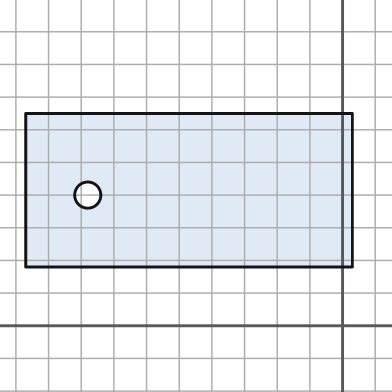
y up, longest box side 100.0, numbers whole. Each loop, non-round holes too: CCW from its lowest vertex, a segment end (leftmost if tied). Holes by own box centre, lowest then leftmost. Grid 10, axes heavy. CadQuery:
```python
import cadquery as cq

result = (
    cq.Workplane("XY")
    .moveTo(-97.0, 18.0)
    .lineTo(3.0, 18.0)
    .lineTo(3.0, 65.0)
    .lineTo(-97.0, 65.0)
    .close()
    .moveTo(-78.0, 40.0)
    .circle(4.0)
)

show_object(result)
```